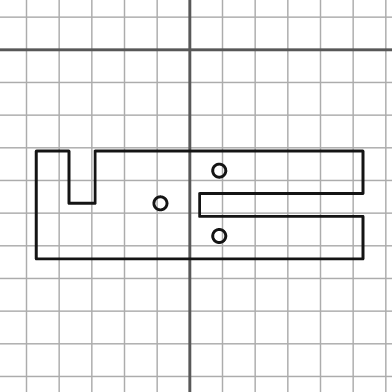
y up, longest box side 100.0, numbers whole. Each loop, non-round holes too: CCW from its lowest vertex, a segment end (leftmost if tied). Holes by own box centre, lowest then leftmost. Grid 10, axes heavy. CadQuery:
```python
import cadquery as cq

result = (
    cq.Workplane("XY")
    .moveTo(-47.0, -64.0)
    .lineTo(53.0, -64.0)
    .lineTo(53.0, -51.0)
    .lineTo(3.0, -51.0)
    .lineTo(3.0, -44.0)
    .lineTo(53.0, -44.0)
    .lineTo(53.0, -31.0)
    .lineTo(-29.0, -31.0)
    .lineTo(-29.0, -47.0)
    .lineTo(-37.0, -47.0)
    .lineTo(-37.0, -31.0)
    .lineTo(-47.0, -31.0)
    .close()
    .moveTo(9.0, -57.0)
    .circle(2.0)
    .moveTo(-9.0, -47.0)
    .circle(2.0)
    .moveTo(9.0, -37.0)
    .circle(2.0)
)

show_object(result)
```